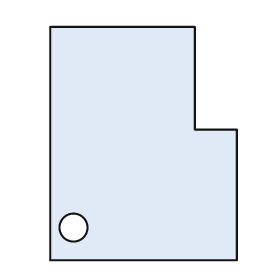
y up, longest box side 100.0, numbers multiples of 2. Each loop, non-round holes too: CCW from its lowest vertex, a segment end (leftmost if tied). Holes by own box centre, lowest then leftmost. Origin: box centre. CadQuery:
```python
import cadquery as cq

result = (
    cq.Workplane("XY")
    .moveTo(-40.0, -50.0)
    .lineTo(40.0, -50.0)
    .lineTo(40.0, 6.0)
    .lineTo(22.0, 6.0)
    .lineTo(22.0, 50.0)
    .lineTo(-40.0, 50.0)
    .close()
    .moveTo(-30.0, -36.0)
    .circle(6.0)
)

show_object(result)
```